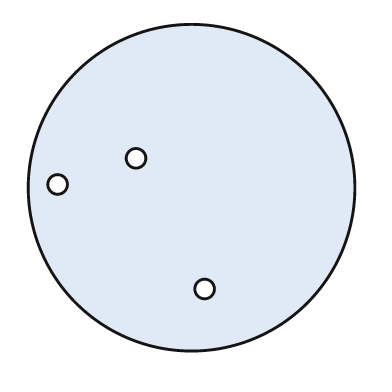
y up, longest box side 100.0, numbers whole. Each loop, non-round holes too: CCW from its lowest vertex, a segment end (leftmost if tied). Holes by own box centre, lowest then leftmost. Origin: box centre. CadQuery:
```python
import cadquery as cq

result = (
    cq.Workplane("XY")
    .moveTo(0.0, 0.0)
    .circle(50.0)
    .moveTo(4.0, -31.0)
    .circle(3.0)
    .moveTo(-41.0, 1.0)
    .circle(3.0)
    .moveTo(-17.0, 9.0)
    .circle(3.0)
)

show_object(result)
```